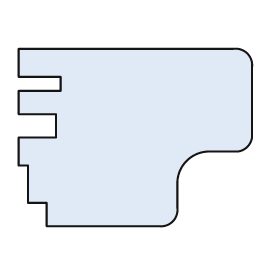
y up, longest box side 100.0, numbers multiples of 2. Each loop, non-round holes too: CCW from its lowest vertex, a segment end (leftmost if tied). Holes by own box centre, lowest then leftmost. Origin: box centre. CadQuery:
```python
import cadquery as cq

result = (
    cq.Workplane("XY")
    .moveTo(-38.0, -38.0)
    .lineTo(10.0, -38.0)
    .threePointArc((16.0, -36.0), (18.0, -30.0))
    .lineTo(18.0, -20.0)
    .threePointArc((22.0, -10.0), (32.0, -6.0))
    .lineTo(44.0, -6.0)
    .threePointArc((48.0, -4.0), (50.0, 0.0))
    .lineTo(50.0, 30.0)
    .threePointArc((48.0, 36.0), (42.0, 38.0))
    .lineTo(-50.0, 38.0)
    .lineTo(-50.0, 26.0)
    .lineTo(-32.0, 26.0)
    .lineTo(-32.0, 20.0)
    .lineTo(-50.0, 20.0)
    .lineTo(-50.0, 10.0)
    .lineTo(-34.0, 10.0)
    .lineTo(-34.0, 0.0)
    .lineTo(-50.0, 0.0)
    .lineTo(-50.0, -12.0)
    .lineTo(-46.0, -12.0)
    .lineTo(-46.0, -28.0)
    .lineTo(-38.0, -28.0)
    .close()
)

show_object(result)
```